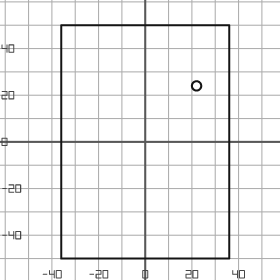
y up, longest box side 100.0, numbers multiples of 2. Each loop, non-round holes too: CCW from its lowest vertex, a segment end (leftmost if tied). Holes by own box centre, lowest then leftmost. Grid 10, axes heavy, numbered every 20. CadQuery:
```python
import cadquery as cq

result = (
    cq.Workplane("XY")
    .moveTo(-36.0, -50.0)
    .lineTo(36.0, -50.0)
    .lineTo(36.0, 50.0)
    .lineTo(-36.0, 50.0)
    .close()
    .moveTo(22.0, 24.0)
    .circle(2.0)
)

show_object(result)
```